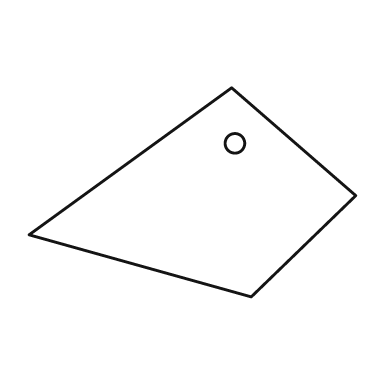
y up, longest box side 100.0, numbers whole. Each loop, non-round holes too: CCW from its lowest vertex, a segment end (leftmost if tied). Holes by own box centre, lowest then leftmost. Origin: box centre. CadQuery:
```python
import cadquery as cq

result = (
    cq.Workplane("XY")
    .moveTo(18.0, -32.0)
    .lineTo(50.0, -1.0)
    .lineTo(12.0, 32.0)
    .lineTo(-50.0, -13.0)
    .close()
    .moveTo(13.0, 15.0)
    .circle(3.0)
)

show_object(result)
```